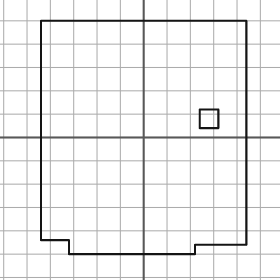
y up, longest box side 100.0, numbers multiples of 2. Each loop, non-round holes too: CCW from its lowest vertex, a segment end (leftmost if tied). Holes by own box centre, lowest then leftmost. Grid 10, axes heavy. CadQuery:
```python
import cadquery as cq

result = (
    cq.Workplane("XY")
    .moveTo(-32.0, -50.0)
    .lineTo(22.0, -50.0)
    .lineTo(22.0, -46.0)
    .lineTo(44.0, -46.0)
    .lineTo(44.0, 50.0)
    .lineTo(-44.0, 50.0)
    .lineTo(-44.0, -44.0)
    .lineTo(-32.0, -44.0)
    .close()
    .moveTo(24.0, 4.0)
    .lineTo(32.0, 4.0)
    .lineTo(32.0, 12.0)
    .lineTo(24.0, 12.0)
    .close()
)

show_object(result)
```